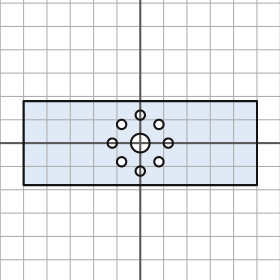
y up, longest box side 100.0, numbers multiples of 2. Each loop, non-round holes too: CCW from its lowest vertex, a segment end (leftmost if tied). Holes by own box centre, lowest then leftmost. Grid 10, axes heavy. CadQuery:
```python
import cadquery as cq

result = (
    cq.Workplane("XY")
    .moveTo(-50.0, -18.0)
    .lineTo(50.0, -18.0)
    .lineTo(50.0, 18.0)
    .lineTo(-50.0, 18.0)
    .close()
    .moveTo(0.0, -12.0)
    .circle(2.0)
    .moveTo(-8.0, -8.0)
    .circle(2.0)
    .moveTo(8.0, -8.0)
    .circle(2.0)
    .moveTo(-12.0, 0.0)
    .circle(2.0)
    .moveTo(0.0, 0.0)
    .circle(4.0)
    .moveTo(12.0, 0.0)
    .circle(2.0)
    .moveTo(-8.0, 8.0)
    .circle(2.0)
    .moveTo(8.0, 8.0)
    .circle(2.0)
    .moveTo(0.0, 12.0)
    .circle(2.0)
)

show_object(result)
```